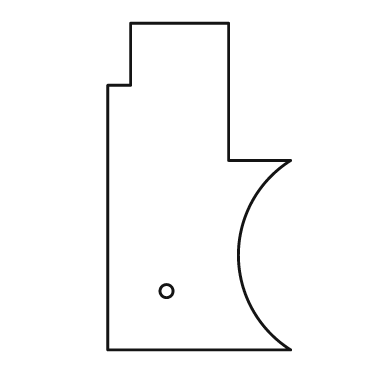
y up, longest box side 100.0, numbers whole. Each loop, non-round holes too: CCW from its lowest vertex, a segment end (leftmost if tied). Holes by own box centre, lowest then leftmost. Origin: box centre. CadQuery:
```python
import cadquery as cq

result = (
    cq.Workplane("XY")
    .moveTo(-28.0, -50.0)
    .lineTo(28.0, -50.0)
    .threePointArc((12.0, -21.0), (28.0, 8.0))
    .lineTo(9.0, 8.0)
    .lineTo(9.0, 50.0)
    .lineTo(-21.0, 50.0)
    .lineTo(-21.0, 31.0)
    .lineTo(-28.0, 31.0)
    .close()
    .moveTo(-10.0, -32.0)
    .circle(2.0)
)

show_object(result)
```